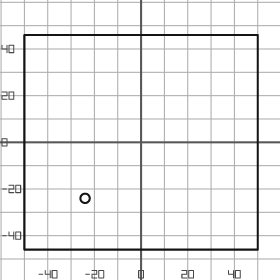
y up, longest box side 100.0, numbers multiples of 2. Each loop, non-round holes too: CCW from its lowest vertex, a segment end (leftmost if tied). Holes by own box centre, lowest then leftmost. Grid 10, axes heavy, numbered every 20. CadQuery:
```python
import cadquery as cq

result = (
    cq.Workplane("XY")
    .moveTo(-50.0, -46.0)
    .lineTo(50.0, -46.0)
    .lineTo(50.0, 46.0)
    .lineTo(-50.0, 46.0)
    .close()
    .moveTo(-24.0, -24.0)
    .circle(2.0)
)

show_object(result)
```